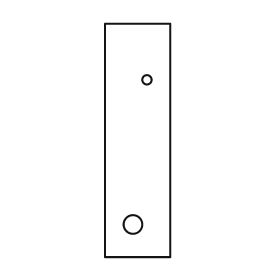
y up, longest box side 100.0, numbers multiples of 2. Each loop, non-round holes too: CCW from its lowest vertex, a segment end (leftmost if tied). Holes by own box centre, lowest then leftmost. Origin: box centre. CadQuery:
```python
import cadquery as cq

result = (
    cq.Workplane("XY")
    .moveTo(-14.0, -50.0)
    .lineTo(14.0, -50.0)
    .lineTo(14.0, 50.0)
    .lineTo(-14.0, 50.0)
    .close()
    .moveTo(-2.0, -36.0)
    .circle(4.0)
    .moveTo(4.0, 26.0)
    .circle(2.0)
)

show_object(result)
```